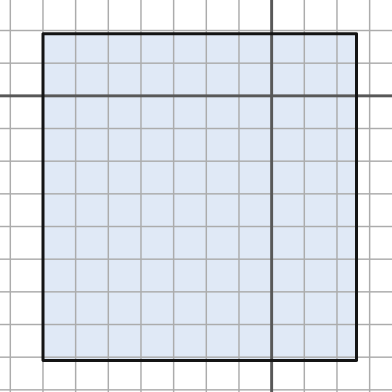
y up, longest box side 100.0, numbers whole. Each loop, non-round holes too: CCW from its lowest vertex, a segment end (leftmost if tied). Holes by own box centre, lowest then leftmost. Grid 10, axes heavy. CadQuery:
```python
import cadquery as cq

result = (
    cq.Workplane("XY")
    .moveTo(-70.0, -81.0)
    .lineTo(26.0, -81.0)
    .lineTo(26.0, 19.0)
    .lineTo(-70.0, 19.0)
    .close()
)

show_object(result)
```